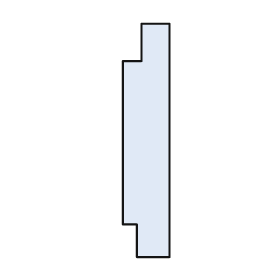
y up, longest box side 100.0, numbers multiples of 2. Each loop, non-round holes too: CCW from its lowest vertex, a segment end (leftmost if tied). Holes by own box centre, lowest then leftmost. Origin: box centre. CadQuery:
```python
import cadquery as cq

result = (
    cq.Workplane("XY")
    .moveTo(-4.0, -50.0)
    .lineTo(10.0, -50.0)
    .lineTo(10.0, 50.0)
    .lineTo(-2.0, 50.0)
    .lineTo(-2.0, 34.0)
    .lineTo(-10.0, 34.0)
    .lineTo(-10.0, -36.0)
    .lineTo(-4.0, -36.0)
    .close()
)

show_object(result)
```